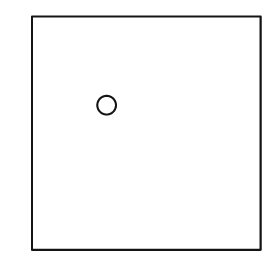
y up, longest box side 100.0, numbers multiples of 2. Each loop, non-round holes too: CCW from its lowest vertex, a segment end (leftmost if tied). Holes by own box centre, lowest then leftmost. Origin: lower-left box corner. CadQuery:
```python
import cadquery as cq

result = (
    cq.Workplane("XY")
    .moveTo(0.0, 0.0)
    .lineTo(98.0, 0.0)
    .lineTo(98.0, 100.0)
    .lineTo(0.0, 100.0)
    .close()
    .moveTo(32.0, 62.0)
    .circle(4.0)
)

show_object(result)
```